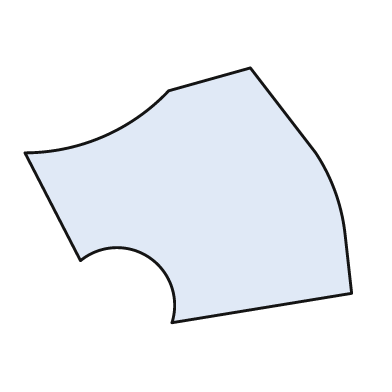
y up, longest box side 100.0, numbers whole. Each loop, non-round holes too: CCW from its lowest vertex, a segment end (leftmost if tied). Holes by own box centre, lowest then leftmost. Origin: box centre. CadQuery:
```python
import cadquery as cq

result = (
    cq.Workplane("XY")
    .moveTo(-5.0, -39.0)
    .lineTo(50.0, -30.0)
    .lineTo(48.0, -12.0)
    .threePointArc((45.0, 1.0), (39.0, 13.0))
    .lineTo(19.0, 39.0)
    .lineTo(-6.0, 32.0)
    .threePointArc((-26.0, 18.0), (-50.0, 13.0))
    .lineTo(-33.0, -20.0)
    .threePointArc((-12.0, -19.0), (-5.0, -39.0))
    .close()
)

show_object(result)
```